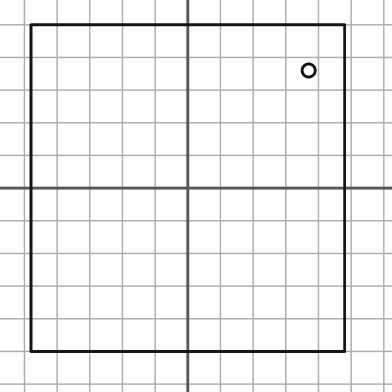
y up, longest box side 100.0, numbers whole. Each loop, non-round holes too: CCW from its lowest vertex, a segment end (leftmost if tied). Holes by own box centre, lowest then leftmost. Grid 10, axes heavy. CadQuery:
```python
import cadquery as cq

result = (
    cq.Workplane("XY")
    .moveTo(-48.0, -50.0)
    .lineTo(48.0, -50.0)
    .lineTo(48.0, 50.0)
    .lineTo(-48.0, 50.0)
    .close()
    .moveTo(37.0, 36.0)
    .circle(2.0)
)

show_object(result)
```